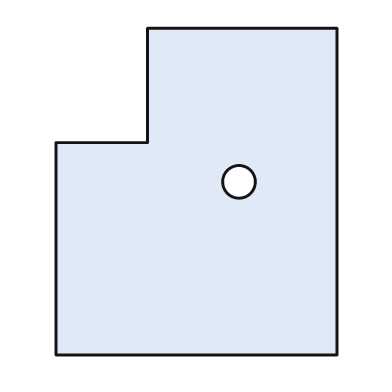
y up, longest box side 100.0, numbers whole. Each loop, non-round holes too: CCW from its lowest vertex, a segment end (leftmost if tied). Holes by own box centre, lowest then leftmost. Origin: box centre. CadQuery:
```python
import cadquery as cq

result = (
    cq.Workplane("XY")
    .moveTo(-43.0, -50.0)
    .lineTo(43.0, -50.0)
    .lineTo(43.0, 50.0)
    .lineTo(-15.0, 50.0)
    .lineTo(-15.0, 15.0)
    .lineTo(-43.0, 15.0)
    .close()
    .moveTo(13.0, 3.0)
    .circle(5.0)
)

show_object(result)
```